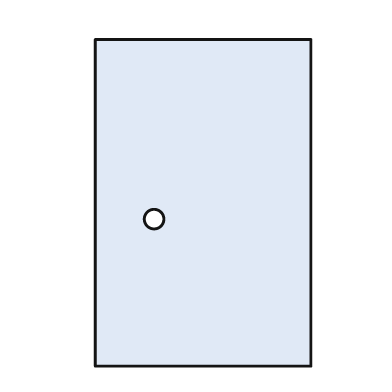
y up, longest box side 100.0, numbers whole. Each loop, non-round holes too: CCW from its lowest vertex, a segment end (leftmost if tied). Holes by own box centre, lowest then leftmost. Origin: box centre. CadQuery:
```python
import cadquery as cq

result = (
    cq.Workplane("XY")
    .moveTo(-33.0, -50.0)
    .lineTo(33.0, -50.0)
    .lineTo(33.0, 50.0)
    .lineTo(-33.0, 50.0)
    .close()
    .moveTo(-15.0, -5.0)
    .circle(3.0)
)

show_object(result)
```